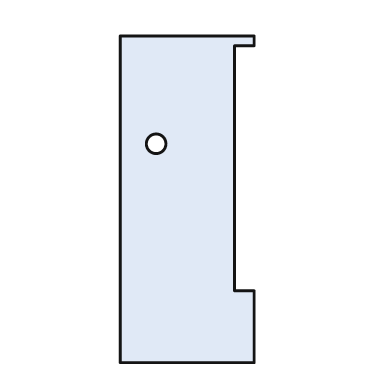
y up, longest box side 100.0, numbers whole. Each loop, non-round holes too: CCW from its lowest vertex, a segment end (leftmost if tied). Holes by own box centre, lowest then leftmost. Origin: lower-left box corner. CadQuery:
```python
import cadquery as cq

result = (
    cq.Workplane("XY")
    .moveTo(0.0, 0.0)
    .lineTo(41.0, 0.0)
    .lineTo(41.0, 22.0)
    .lineTo(35.0, 22.0)
    .lineTo(35.0, 97.0)
    .lineTo(41.0, 97.0)
    .lineTo(41.0, 100.0)
    .lineTo(0.0, 100.0)
    .close()
    .moveTo(11.0, 67.0)
    .circle(3.0)
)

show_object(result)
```